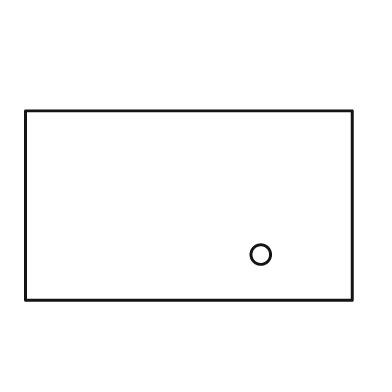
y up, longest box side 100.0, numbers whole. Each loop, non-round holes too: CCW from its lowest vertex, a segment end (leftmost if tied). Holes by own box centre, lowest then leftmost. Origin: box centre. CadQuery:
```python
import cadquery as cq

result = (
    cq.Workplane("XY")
    .moveTo(-50.0, -29.0)
    .lineTo(50.0, -29.0)
    .lineTo(50.0, 29.0)
    .lineTo(-50.0, 29.0)
    .close()
    .moveTo(22.0, -15.0)
    .circle(3.0)
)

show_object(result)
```